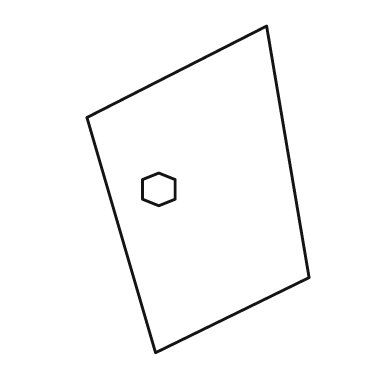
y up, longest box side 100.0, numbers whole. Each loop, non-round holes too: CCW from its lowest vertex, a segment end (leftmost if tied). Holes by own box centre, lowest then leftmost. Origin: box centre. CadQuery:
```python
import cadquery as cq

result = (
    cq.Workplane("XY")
    .moveTo(-13.0, -50.0)
    .lineTo(34.0, -27.0)
    .lineTo(21.0, 50.0)
    .lineTo(-34.0, 22.0)
    .close()
    .moveTo(-12.0, -5.0)
    .lineTo(-7.0, -3.0)
    .lineTo(-7.0, 3.0)
    .lineTo(-12.0, 5.0)
    .lineTo(-17.0, 3.0)
    .lineTo(-17.0, -3.0)
    .close()
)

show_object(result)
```